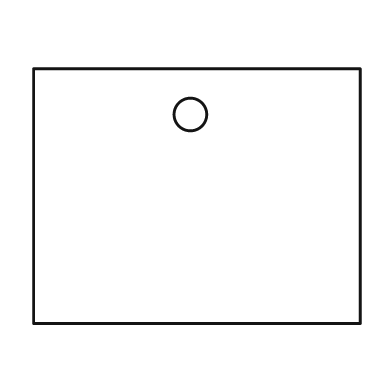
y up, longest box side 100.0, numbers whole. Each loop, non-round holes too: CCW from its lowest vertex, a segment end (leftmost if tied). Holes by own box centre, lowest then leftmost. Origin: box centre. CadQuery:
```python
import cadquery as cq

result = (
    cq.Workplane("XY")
    .moveTo(-50.0, -39.0)
    .lineTo(50.0, -39.0)
    .lineTo(50.0, 39.0)
    .lineTo(-50.0, 39.0)
    .close()
    .moveTo(-2.0, 25.0)
    .circle(5.0)
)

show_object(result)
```